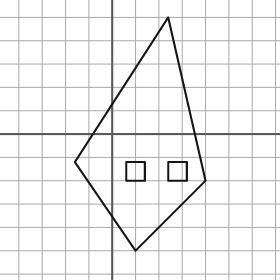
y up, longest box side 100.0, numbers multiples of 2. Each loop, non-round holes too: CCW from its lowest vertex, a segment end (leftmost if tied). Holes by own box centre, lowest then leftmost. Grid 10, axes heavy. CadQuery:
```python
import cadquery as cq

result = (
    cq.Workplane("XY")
    .moveTo(10.0, -50.0)
    .lineTo(40.0, -20.0)
    .lineTo(24.0, 50.0)
    .lineTo(-16.0, -12.0)
    .close()
    .moveTo(6.0, -20.0)
    .lineTo(14.0, -20.0)
    .lineTo(14.0, -12.0)
    .lineTo(6.0, -12.0)
    .close()
    .moveTo(24.0, -20.0)
    .lineTo(32.0, -20.0)
    .lineTo(32.0, -12.0)
    .lineTo(24.0, -12.0)
    .close()
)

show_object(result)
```